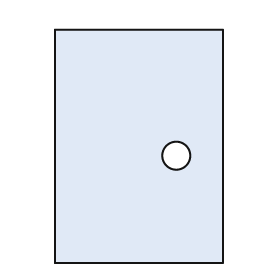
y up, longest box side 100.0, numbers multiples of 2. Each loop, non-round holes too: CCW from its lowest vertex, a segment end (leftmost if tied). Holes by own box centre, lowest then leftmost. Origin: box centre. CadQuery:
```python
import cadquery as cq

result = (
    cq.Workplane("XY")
    .moveTo(-36.0, -50.0)
    .lineTo(36.0, -50.0)
    .lineTo(36.0, 50.0)
    .lineTo(-36.0, 50.0)
    .close()
    .moveTo(16.0, -4.0)
    .circle(6.0)
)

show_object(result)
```